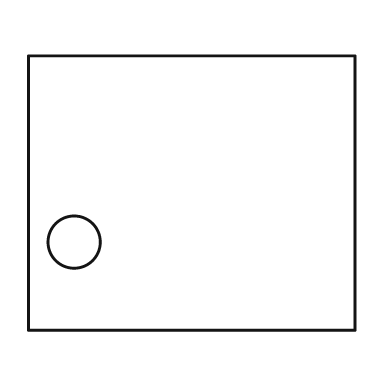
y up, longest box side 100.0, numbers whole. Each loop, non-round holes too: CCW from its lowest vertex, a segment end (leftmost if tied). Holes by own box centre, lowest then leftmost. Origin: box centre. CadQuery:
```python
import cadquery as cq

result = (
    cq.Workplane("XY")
    .moveTo(-50.0, -42.0)
    .lineTo(50.0, -42.0)
    .lineTo(50.0, 42.0)
    .lineTo(-50.0, 42.0)
    .close()
    .moveTo(-36.0, -15.0)
    .circle(8.0)
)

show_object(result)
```